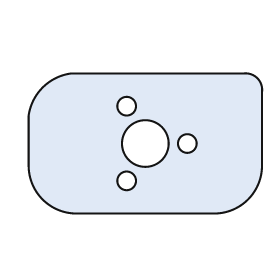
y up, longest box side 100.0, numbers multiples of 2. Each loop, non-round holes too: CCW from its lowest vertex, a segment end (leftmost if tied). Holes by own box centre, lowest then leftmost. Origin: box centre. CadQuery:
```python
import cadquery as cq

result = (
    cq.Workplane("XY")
    .moveTo(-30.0, -30.0)
    .lineTo(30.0, -30.0)
    .threePointArc((44.0, -24.0), (50.0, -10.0))
    .lineTo(50.0, 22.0)
    .threePointArc((48.0, 28.0), (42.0, 30.0))
    .lineTo(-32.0, 30.0)
    .threePointArc((-44.0, 24.0), (-50.0, 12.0))
    .lineTo(-50.0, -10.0)
    .threePointArc((-44.0, -24.0), (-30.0, -30.0))
    .close()
    .moveTo(-8.0, -16.0)
    .circle(4.0)
    .moveTo(0.0, 0.0)
    .circle(10.0)
    .moveTo(18.0, 0.0)
    .circle(4.0)
    .moveTo(-8.0, 16.0)
    .circle(4.0)
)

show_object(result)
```